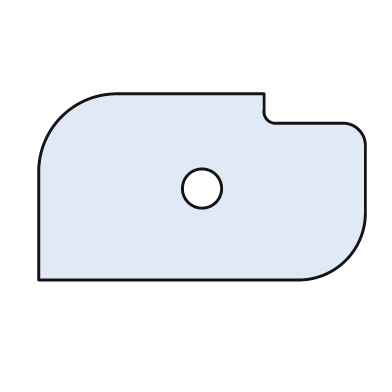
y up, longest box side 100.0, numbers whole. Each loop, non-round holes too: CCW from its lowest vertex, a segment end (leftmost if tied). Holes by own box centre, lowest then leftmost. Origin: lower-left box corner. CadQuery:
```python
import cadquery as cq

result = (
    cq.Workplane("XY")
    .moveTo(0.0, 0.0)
    .lineTo(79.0, 0.0)
    .threePointArc((94.0, 6.0), (100.0, 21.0))
    .lineTo(100.0, 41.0)
    .threePointArc((98.0, 46.0), (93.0, 48.0))
    .lineTo(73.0, 48.0)
    .threePointArc((70.0, 49.0), (69.0, 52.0))
    .lineTo(69.0, 57.0)
    .lineTo(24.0, 57.0)
    .threePointArc((7.0, 50.0), (0.0, 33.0))
    .close()
    .moveTo(50.0, 28.0)
    .circle(6.0)
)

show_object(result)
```